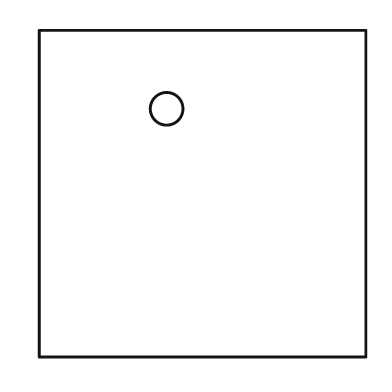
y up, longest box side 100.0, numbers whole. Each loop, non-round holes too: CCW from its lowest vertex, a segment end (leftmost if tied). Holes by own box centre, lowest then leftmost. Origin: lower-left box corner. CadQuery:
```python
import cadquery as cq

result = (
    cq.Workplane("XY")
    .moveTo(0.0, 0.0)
    .lineTo(100.0, 0.0)
    .lineTo(100.0, 100.0)
    .lineTo(0.0, 100.0)
    .close()
    .moveTo(39.0, 76.0)
    .circle(5.0)
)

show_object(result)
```